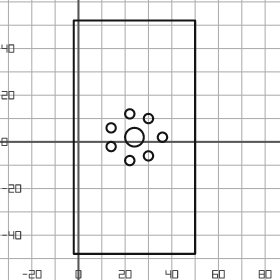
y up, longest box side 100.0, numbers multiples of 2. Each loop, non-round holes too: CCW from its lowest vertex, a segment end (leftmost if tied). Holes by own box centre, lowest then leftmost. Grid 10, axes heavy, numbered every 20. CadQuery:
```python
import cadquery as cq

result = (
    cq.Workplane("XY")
    .moveTo(-2.0, -48.0)
    .lineTo(50.0, -48.0)
    .lineTo(50.0, 52.0)
    .lineTo(-2.0, 52.0)
    .close()
    .moveTo(22.0, -8.0)
    .circle(2.0)
    .moveTo(30.0, -6.0)
    .circle(2.0)
    .moveTo(14.0, -2.0)
    .circle(2.0)
    .moveTo(24.0, 2.0)
    .circle(4.0)
    .moveTo(36.0, 2.0)
    .circle(2.0)
    .moveTo(14.0, 6.0)
    .circle(2.0)
    .moveTo(30.0, 10.0)
    .circle(2.0)
    .moveTo(22.0, 12.0)
    .circle(2.0)
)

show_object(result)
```